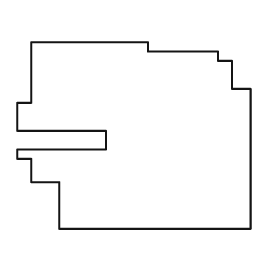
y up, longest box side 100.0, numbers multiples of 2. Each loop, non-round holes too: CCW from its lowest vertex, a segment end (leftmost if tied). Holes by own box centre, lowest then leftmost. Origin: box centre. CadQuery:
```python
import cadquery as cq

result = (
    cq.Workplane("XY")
    .moveTo(-32.0, -40.0)
    .lineTo(50.0, -40.0)
    .lineTo(50.0, 20.0)
    .lineTo(42.0, 20.0)
    .lineTo(42.0, 32.0)
    .lineTo(36.0, 32.0)
    .lineTo(36.0, 36.0)
    .lineTo(6.0, 36.0)
    .lineTo(6.0, 40.0)
    .lineTo(-44.0, 40.0)
    .lineTo(-44.0, 14.0)
    .lineTo(-50.0, 14.0)
    .lineTo(-50.0, 2.0)
    .lineTo(-12.0, 2.0)
    .lineTo(-12.0, -6.0)
    .lineTo(-50.0, -6.0)
    .lineTo(-50.0, -10.0)
    .lineTo(-44.0, -10.0)
    .lineTo(-44.0, -20.0)
    .lineTo(-32.0, -20.0)
    .close()
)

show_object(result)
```